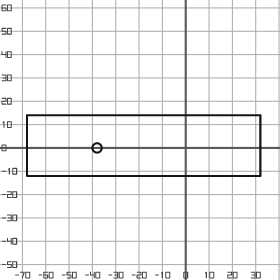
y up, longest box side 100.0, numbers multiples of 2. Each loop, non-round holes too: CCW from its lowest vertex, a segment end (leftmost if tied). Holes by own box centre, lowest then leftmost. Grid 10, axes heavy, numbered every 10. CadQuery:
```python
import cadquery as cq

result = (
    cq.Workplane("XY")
    .moveTo(-68.0, -12.0)
    .lineTo(32.0, -12.0)
    .lineTo(32.0, 14.0)
    .lineTo(-68.0, 14.0)
    .close()
    .moveTo(-38.0, 0.0)
    .circle(2.0)
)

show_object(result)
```